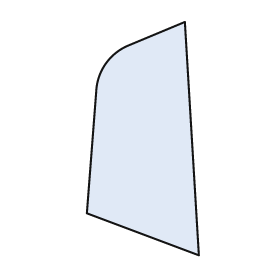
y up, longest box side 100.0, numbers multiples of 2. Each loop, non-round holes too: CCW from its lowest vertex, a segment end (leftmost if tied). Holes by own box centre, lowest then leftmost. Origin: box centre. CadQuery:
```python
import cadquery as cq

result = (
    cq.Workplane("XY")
    .moveTo(24.0, -50.0)
    .lineTo(18.0, 50.0)
    .lineTo(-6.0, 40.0)
    .threePointArc((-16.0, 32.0), (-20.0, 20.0))
    .lineTo(-24.0, -32.0)
    .close()
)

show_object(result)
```